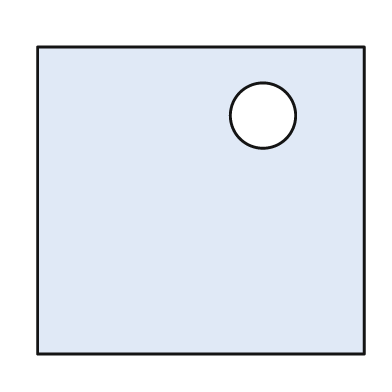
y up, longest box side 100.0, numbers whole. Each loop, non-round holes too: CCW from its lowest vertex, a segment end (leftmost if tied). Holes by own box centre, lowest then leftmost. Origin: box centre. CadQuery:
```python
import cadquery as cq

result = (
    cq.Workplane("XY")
    .moveTo(-50.0, -47.0)
    .lineTo(50.0, -47.0)
    .lineTo(50.0, 47.0)
    .lineTo(-50.0, 47.0)
    .close()
    .moveTo(19.0, 26.0)
    .circle(10.0)
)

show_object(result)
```